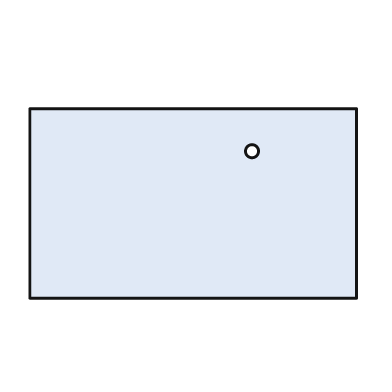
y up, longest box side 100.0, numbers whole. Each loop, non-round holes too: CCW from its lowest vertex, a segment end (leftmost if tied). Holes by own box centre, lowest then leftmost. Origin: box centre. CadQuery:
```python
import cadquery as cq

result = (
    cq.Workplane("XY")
    .moveTo(-50.0, -29.0)
    .lineTo(50.0, -29.0)
    .lineTo(50.0, 29.0)
    .lineTo(-50.0, 29.0)
    .close()
    .moveTo(18.0, 16.0)
    .circle(2.0)
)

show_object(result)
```